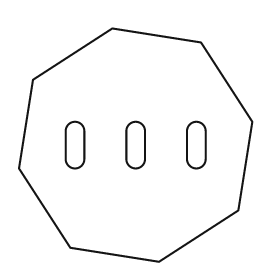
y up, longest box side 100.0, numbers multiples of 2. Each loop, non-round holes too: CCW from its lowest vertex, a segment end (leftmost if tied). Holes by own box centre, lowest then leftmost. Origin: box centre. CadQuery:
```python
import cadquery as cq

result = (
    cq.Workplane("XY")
    .moveTo(10.0, -50.0)
    .lineTo(44.0, -28.0)
    .lineTo(50.0, 10.0)
    .lineTo(28.0, 44.0)
    .lineTo(-10.0, 50.0)
    .lineTo(-44.0, 28.0)
    .lineTo(-50.0, -10.0)
    .lineTo(-28.0, -44.0)
    .close()
    .moveTo(-30.0, -6.0)
    .threePointArc((-26.0, -10.0), (-22.0, -6.0))
    .lineTo(-22.0, 6.0)
    .threePointArc((-26.0, 10.0), (-30.0, 6.0))
    .close()
    .moveTo(-4.0, -6.0)
    .threePointArc((0.0, -10.0), (4.0, -6.0))
    .lineTo(4.0, 6.0)
    .threePointArc((0.0, 10.0), (-4.0, 6.0))
    .close()
    .moveTo(22.0, -6.0)
    .threePointArc((26.0, -10.0), (30.0, -6.0))
    .lineTo(30.0, 6.0)
    .threePointArc((26.0, 10.0), (22.0, 6.0))
    .close()
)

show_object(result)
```